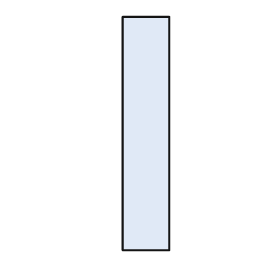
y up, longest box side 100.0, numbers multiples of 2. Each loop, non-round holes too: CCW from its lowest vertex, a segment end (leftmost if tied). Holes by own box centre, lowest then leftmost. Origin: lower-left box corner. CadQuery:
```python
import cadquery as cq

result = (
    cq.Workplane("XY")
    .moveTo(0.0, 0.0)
    .lineTo(20.0, 0.0)
    .lineTo(20.0, 100.0)
    .lineTo(0.0, 100.0)
    .close()
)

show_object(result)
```